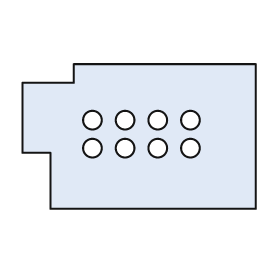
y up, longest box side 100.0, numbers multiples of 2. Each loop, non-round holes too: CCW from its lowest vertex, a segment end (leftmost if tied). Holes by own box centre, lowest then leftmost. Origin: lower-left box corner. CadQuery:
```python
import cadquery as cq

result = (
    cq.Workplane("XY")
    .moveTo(12.0, 0.0)
    .lineTo(100.0, 0.0)
    .lineTo(100.0, 62.0)
    .lineTo(22.0, 62.0)
    .lineTo(22.0, 54.0)
    .lineTo(0.0, 54.0)
    .lineTo(0.0, 24.0)
    .lineTo(12.0, 24.0)
    .close()
    .moveTo(30.0, 26.0)
    .circle(4.0)
    .moveTo(44.0, 26.0)
    .circle(4.0)
    .moveTo(58.0, 26.0)
    .circle(4.0)
    .moveTo(72.0, 26.0)
    .circle(4.0)
    .moveTo(30.0, 38.0)
    .circle(4.0)
    .moveTo(44.0, 38.0)
    .circle(4.0)
    .moveTo(58.0, 38.0)
    .circle(4.0)
    .moveTo(72.0, 38.0)
    .circle(4.0)
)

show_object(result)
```